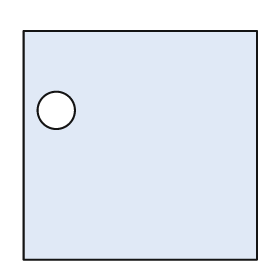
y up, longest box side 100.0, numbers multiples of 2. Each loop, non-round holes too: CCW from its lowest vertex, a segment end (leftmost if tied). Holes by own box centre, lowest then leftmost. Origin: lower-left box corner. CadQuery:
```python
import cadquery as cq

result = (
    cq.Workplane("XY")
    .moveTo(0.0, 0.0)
    .lineTo(100.0, 0.0)
    .lineTo(100.0, 98.0)
    .lineTo(0.0, 98.0)
    .close()
    .moveTo(14.0, 64.0)
    .circle(8.0)
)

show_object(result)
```